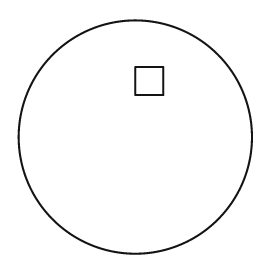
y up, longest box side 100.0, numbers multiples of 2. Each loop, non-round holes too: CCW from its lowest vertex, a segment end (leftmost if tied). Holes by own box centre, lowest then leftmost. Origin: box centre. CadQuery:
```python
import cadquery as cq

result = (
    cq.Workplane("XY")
    .moveTo(0.0, 0.0)
    .circle(50.0)
    .moveTo(0.0, 18.0)
    .lineTo(12.0, 18.0)
    .lineTo(12.0, 30.0)
    .lineTo(0.0, 30.0)
    .close()
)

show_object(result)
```